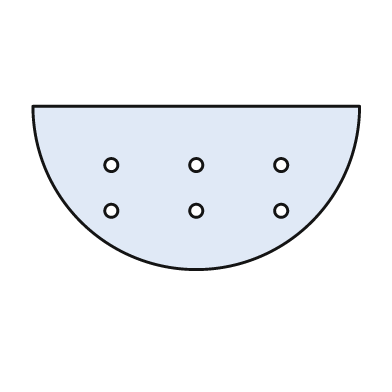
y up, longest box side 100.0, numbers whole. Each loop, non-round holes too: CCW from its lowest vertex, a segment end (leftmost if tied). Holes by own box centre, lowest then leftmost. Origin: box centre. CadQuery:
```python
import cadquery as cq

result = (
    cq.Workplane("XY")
    .moveTo(-50.0, 25.0)
    .threePointArc((0.0, -25.0), (50.0, 25.0))
    .close()
    .moveTo(-26.0, -7.0)
    .circle(2.0)
    .moveTo(0.0, -7.0)
    .circle(2.0)
    .moveTo(26.0, -7.0)
    .circle(2.0)
    .moveTo(-26.0, 7.0)
    .circle(2.0)
    .moveTo(0.0, 7.0)
    .circle(2.0)
    .moveTo(26.0, 7.0)
    .circle(2.0)
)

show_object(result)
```